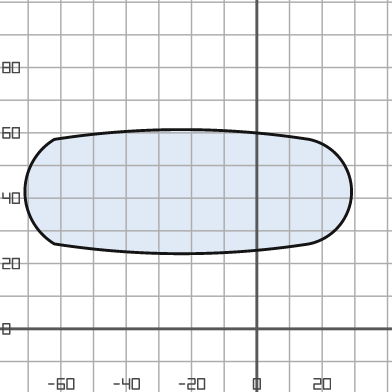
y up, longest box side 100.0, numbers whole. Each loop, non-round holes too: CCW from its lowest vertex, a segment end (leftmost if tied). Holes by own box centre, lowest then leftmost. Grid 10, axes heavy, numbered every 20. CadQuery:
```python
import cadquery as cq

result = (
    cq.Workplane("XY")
    .moveTo(-62.0, 26.0)
    .threePointArc((-23.0, 23.0), (16.0, 26.0))
    .threePointArc((29.0, 42.0), (16.0, 58.0))
    .threePointArc((-23.0, 61.0), (-62.0, 58.0))
    .threePointArc((-71.0, 42.0), (-62.0, 26.0))
    .close()
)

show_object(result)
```